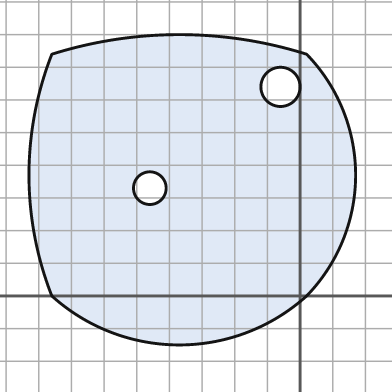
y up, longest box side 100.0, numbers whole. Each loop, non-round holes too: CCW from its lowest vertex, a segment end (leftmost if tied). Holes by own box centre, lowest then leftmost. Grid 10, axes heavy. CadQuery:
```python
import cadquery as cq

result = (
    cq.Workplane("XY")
    .moveTo(-76.0, 0.0)
    .threePointArc((-37.0, -15.0), (2.0, 0.0))
    .threePointArc((17.0, 37.0), (2.0, 74.0))
    .threePointArc((-37.0, 80.0), (-76.0, 74.0))
    .threePointArc((-83.0, 37.0), (-76.0, 0.0))
    .close()
    .moveTo(-46.0, 33.0)
    .circle(5.0)
    .moveTo(-6.0, 64.0)
    .circle(6.0)
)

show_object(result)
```